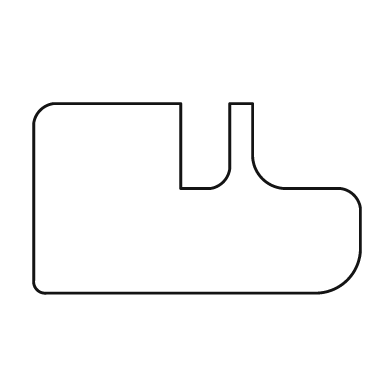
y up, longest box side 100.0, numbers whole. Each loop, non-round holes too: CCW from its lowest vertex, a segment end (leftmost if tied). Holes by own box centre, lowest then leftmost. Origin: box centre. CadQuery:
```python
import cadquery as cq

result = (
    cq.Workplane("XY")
    .moveTo(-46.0, -29.0)
    .lineTo(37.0, -29.0)
    .threePointArc((46.0, -25.0), (50.0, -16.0))
    .lineTo(50.0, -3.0)
    .threePointArc((48.0, 1.0), (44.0, 3.0))
    .lineTo(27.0, 3.0)
    .threePointArc((20.0, 6.0), (17.0, 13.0))
    .lineTo(17.0, 29.0)
    .lineTo(10.0, 29.0)
    .lineTo(10.0, 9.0)
    .threePointArc((8.0, 5.0), (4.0, 3.0))
    .lineTo(-5.0, 3.0)
    .lineTo(-5.0, 29.0)
    .lineTo(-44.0, 29.0)
    .threePointArc((-48.0, 27.0), (-50.0, 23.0))
    .lineTo(-50.0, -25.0)
    .threePointArc((-49.0, -28.0), (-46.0, -29.0))
    .close()
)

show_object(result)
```